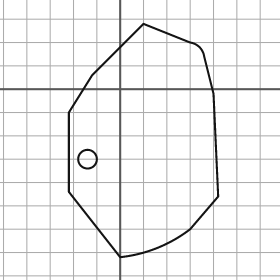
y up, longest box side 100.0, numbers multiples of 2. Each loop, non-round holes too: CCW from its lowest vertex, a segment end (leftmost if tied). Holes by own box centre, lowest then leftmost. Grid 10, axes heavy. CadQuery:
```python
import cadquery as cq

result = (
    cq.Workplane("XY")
    .moveTo(0.0, -72.0)
    .threePointArc((16.0, -68.0), (30.0, -60.0))
    .lineTo(42.0, -46.0)
    .lineTo(40.0, -2.0)
    .lineTo(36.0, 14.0)
    .threePointArc((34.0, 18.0), (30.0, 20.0))
    .lineTo(10.0, 28.0)
    .lineTo(-12.0, 6.0)
    .lineTo(-22.0, -10.0)
    .lineTo(-22.0, -44.0)
    .close()
    .moveTo(-14.0, -30.0)
    .circle(4.0)
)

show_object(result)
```